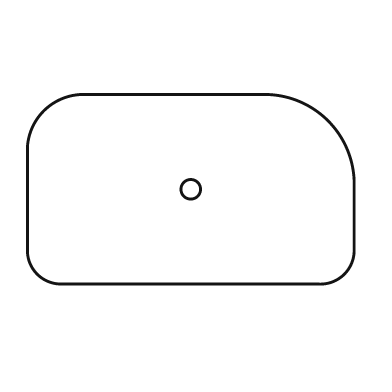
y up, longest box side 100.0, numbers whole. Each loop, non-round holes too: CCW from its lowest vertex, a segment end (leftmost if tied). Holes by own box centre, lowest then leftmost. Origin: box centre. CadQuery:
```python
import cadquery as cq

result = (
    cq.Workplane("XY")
    .moveTo(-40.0, -29.0)
    .lineTo(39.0, -29.0)
    .threePointArc((47.0, -26.0), (50.0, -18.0))
    .lineTo(50.0, 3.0)
    .threePointArc((42.0, 21.0), (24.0, 29.0))
    .lineTo(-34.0, 29.0)
    .threePointArc((-45.0, 24.0), (-50.0, 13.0))
    .lineTo(-50.0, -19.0)
    .threePointArc((-47.0, -26.0), (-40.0, -29.0))
    .close()
    .moveTo(0.0, 0.0)
    .circle(3.0)
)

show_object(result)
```